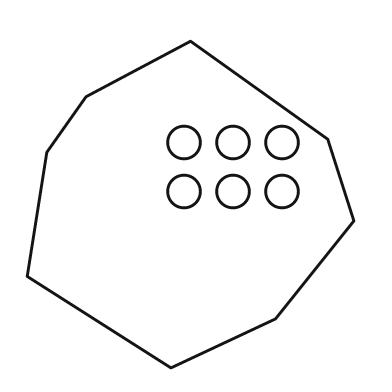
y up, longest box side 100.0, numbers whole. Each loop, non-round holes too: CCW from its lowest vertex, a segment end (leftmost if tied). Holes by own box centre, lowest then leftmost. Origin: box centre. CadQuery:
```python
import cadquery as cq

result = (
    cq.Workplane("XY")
    .moveTo(-6.0, -50.0)
    .lineTo(26.0, -35.0)
    .lineTo(50.0, -5.0)
    .lineTo(42.0, 20.0)
    .lineTo(0.0, 50.0)
    .lineTo(-32.0, 33.0)
    .lineTo(-44.0, 16.0)
    .lineTo(-50.0, -22.0)
    .close()
    .moveTo(-2.0, 4.0)
    .circle(5.0)
    .moveTo(13.0, 4.0)
    .circle(5.0)
    .moveTo(28.0, 4.0)
    .circle(5.0)
    .moveTo(-2.0, 19.0)
    .circle(5.0)
    .moveTo(13.0, 19.0)
    .circle(5.0)
    .moveTo(28.0, 19.0)
    .circle(5.0)
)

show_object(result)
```